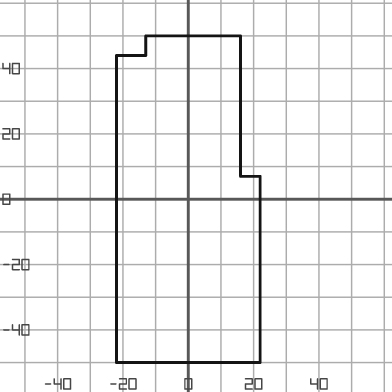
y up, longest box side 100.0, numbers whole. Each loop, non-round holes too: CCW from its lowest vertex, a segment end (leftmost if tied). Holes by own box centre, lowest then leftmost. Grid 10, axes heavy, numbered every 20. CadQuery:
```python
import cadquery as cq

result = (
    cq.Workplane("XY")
    .moveTo(-22.0, -50.0)
    .lineTo(22.0, -50.0)
    .lineTo(22.0, 7.0)
    .lineTo(16.0, 7.0)
    .lineTo(16.0, 50.0)
    .lineTo(-13.0, 50.0)
    .lineTo(-13.0, 44.0)
    .lineTo(-22.0, 44.0)
    .close()
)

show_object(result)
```